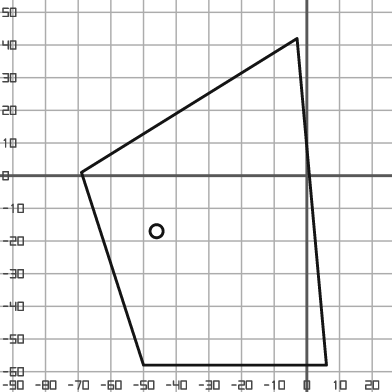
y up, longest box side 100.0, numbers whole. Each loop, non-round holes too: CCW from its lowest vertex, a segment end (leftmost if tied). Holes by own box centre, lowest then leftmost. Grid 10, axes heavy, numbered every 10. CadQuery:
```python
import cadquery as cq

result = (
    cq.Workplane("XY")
    .moveTo(-50.0, -58.0)
    .lineTo(6.0, -58.0)
    .lineTo(-3.0, 42.0)
    .lineTo(-69.0, 1.0)
    .close()
    .moveTo(-46.0, -17.0)
    .circle(2.0)
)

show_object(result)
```